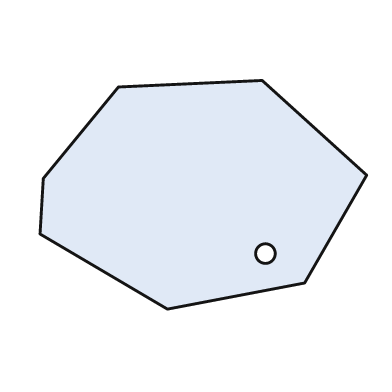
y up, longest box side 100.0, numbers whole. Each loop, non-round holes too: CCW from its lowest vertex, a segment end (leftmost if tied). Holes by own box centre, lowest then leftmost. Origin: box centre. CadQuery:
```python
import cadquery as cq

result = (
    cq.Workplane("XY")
    .moveTo(-11.0, -35.0)
    .lineTo(31.0, -27.0)
    .lineTo(50.0, 6.0)
    .lineTo(18.0, 35.0)
    .lineTo(-26.0, 33.0)
    .lineTo(-49.0, 5.0)
    .lineTo(-50.0, -12.0)
    .close()
    .moveTo(19.0, -18.0)
    .circle(3.0)
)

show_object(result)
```